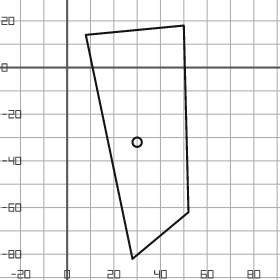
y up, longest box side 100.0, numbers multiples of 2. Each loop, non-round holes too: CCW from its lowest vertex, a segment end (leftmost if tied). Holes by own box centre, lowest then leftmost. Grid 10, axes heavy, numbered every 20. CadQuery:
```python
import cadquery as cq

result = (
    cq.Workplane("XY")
    .moveTo(28.0, -82.0)
    .lineTo(52.0, -62.0)
    .lineTo(50.0, 18.0)
    .lineTo(8.0, 14.0)
    .close()
    .moveTo(30.0, -32.0)
    .circle(2.0)
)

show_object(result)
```